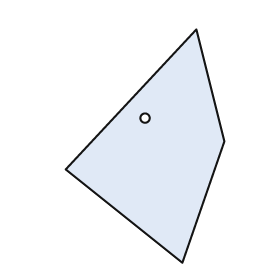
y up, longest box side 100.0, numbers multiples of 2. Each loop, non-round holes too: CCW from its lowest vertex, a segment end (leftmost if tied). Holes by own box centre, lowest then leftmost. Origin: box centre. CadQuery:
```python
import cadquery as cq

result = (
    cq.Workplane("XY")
    .moveTo(16.0, -50.0)
    .lineTo(34.0, 2.0)
    .lineTo(22.0, 50.0)
    .lineTo(-34.0, -10.0)
    .close()
    .moveTo(0.0, 12.0)
    .circle(2.0)
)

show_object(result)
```